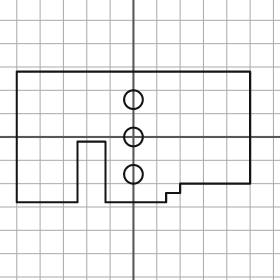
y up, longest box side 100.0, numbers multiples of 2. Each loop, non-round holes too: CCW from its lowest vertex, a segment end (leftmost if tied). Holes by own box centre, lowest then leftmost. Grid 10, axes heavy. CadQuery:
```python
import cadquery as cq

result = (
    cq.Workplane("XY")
    .moveTo(-50.0, -28.0)
    .lineTo(-24.0, -28.0)
    .lineTo(-24.0, -2.0)
    .lineTo(-12.0, -2.0)
    .lineTo(-12.0, -28.0)
    .lineTo(14.0, -28.0)
    .lineTo(14.0, -24.0)
    .lineTo(20.0, -24.0)
    .lineTo(20.0, -20.0)
    .lineTo(50.0, -20.0)
    .lineTo(50.0, 28.0)
    .lineTo(-50.0, 28.0)
    .close()
    .moveTo(0.0, -16.0)
    .circle(4.0)
    .moveTo(0.0, 0.0)
    .circle(4.0)
    .moveTo(0.0, 16.0)
    .circle(4.0)
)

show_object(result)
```